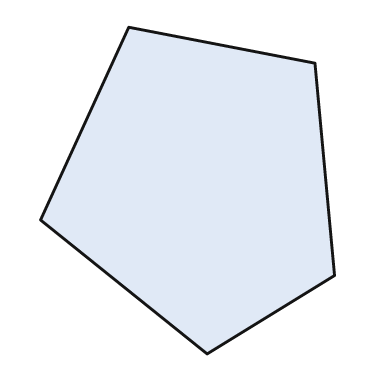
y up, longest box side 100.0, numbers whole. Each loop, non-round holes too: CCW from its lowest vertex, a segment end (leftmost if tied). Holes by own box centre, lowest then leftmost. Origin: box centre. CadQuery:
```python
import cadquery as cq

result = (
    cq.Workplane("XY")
    .moveTo(6.0, -50.0)
    .lineTo(45.0, -26.0)
    .lineTo(39.0, 39.0)
    .lineTo(-18.0, 50.0)
    .lineTo(-45.0, -9.0)
    .close()
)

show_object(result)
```